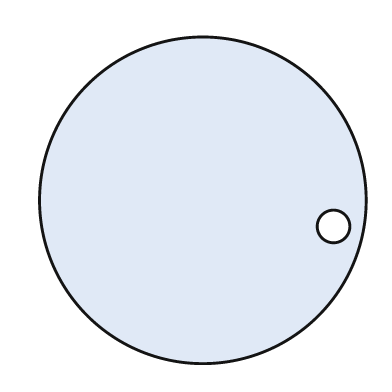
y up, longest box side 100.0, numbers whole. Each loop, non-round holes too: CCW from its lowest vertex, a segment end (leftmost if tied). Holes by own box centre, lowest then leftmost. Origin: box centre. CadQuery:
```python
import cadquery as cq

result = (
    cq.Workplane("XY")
    .moveTo(0.0, 0.0)
    .circle(50.0)
    .moveTo(40.0, -8.0)
    .circle(5.0)
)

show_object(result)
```